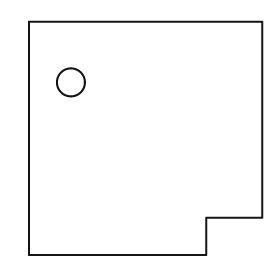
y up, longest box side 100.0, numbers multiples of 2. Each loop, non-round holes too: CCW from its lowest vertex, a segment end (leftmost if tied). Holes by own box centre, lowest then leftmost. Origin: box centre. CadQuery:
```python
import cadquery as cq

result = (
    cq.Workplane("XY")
    .moveTo(-50.0, -50.0)
    .lineTo(26.0, -50.0)
    .lineTo(26.0, -34.0)
    .lineTo(50.0, -34.0)
    .lineTo(50.0, 50.0)
    .lineTo(-50.0, 50.0)
    .close()
    .moveTo(-32.0, 24.0)
    .circle(6.0)
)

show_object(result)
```